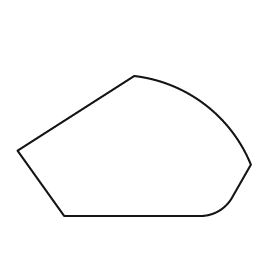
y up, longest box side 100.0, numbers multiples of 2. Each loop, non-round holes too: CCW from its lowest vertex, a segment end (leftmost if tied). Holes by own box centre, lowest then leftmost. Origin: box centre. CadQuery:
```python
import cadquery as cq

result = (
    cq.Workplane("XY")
    .moveTo(-30.0, -30.0)
    .lineTo(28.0, -30.0)
    .threePointArc((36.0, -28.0), (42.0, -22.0))
    .lineTo(50.0, -8.0)
    .threePointArc((30.0, 18.0), (0.0, 30.0))
    .lineTo(-50.0, -2.0)
    .close()
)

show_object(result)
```